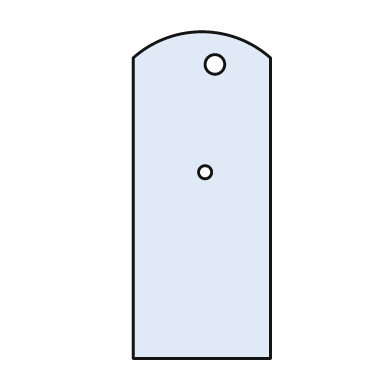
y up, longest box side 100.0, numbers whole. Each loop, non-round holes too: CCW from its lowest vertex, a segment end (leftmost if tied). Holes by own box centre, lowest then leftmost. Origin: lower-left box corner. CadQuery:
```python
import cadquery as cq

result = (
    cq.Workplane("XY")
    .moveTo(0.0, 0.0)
    .lineTo(42.0, 0.0)
    .lineTo(42.0, 92.0)
    .threePointArc((21.0, 100.0), (0.0, 92.0))
    .close()
    .moveTo(22.0, 57.0)
    .circle(2.0)
    .moveTo(25.0, 90.0)
    .circle(3.0)
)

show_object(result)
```